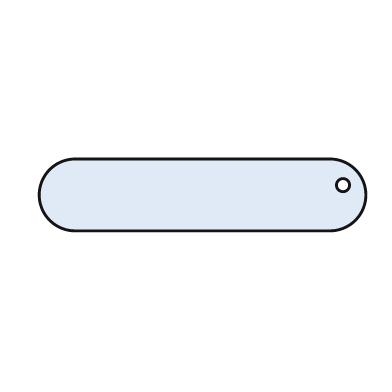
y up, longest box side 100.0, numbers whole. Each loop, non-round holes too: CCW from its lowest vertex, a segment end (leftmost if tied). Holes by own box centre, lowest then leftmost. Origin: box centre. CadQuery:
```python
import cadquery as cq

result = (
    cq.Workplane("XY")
    .moveTo(-39.0, -11.0)
    .lineTo(39.0, -11.0)
    .threePointArc((50.0, 0.0), (39.0, 11.0))
    .lineTo(-39.0, 11.0)
    .threePointArc((-50.0, 0.0), (-39.0, -11.0))
    .close()
    .moveTo(43.0, 3.0)
    .circle(2.0)
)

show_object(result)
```